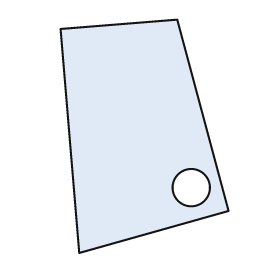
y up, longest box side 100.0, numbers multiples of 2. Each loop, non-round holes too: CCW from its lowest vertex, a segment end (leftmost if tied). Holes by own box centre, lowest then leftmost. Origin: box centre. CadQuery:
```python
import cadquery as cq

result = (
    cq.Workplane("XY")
    .moveTo(-28.0, -50.0)
    .lineTo(36.0, -32.0)
    .lineTo(14.0, 50.0)
    .lineTo(-36.0, 46.0)
    .close()
    .moveTo(20.0, -22.0)
    .circle(8.0)
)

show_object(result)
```